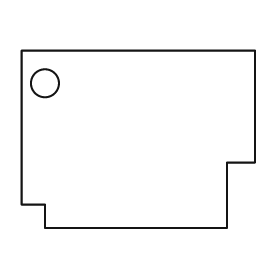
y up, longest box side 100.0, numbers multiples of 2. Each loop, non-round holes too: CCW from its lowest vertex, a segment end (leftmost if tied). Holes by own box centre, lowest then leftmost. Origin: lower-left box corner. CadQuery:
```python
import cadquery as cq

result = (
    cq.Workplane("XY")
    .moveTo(10.0, 0.0)
    .lineTo(88.0, 0.0)
    .lineTo(88.0, 28.0)
    .lineTo(100.0, 28.0)
    .lineTo(100.0, 76.0)
    .lineTo(0.0, 76.0)
    .lineTo(0.0, 10.0)
    .lineTo(10.0, 10.0)
    .close()
    .moveTo(10.0, 62.0)
    .circle(6.0)
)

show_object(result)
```